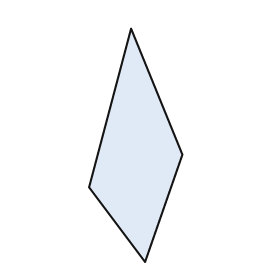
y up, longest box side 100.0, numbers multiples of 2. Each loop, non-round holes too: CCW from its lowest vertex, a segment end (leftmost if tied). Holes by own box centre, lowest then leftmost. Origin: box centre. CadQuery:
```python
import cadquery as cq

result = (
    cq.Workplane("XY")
    .moveTo(4.0, -50.0)
    .lineTo(20.0, -4.0)
    .lineTo(-2.0, 50.0)
    .lineTo(-20.0, -18.0)
    .close()
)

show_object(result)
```